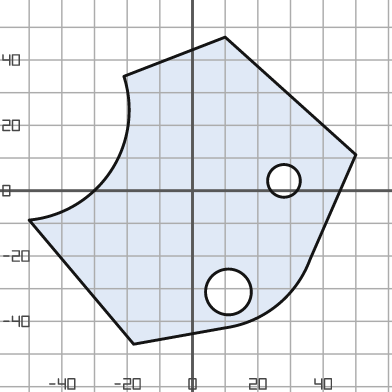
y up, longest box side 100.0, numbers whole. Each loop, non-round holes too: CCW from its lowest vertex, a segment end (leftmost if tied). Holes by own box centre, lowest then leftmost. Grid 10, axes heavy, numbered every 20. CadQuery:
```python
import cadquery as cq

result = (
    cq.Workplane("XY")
    .moveTo(-18.0, -47.0)
    .lineTo(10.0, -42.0)
    .threePointArc((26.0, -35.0), (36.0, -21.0))
    .lineTo(50.0, 11.0)
    .lineTo(10.0, 47.0)
    .lineTo(-21.0, 35.0)
    .threePointArc((-25.0, 6.0), (-50.0, -9.0))
    .close()
    .moveTo(11.0, -31.0)
    .circle(7.0)
    .moveTo(28.0, 3.0)
    .circle(5.0)
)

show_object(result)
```